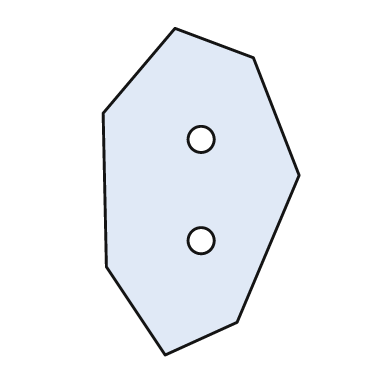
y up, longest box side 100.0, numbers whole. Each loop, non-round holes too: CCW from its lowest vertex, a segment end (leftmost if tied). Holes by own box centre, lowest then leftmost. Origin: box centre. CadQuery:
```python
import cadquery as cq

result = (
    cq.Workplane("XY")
    .moveTo(-11.0, -50.0)
    .lineTo(11.0, -40.0)
    .lineTo(30.0, 5.0)
    .lineTo(16.0, 41.0)
    .lineTo(-8.0, 50.0)
    .lineTo(-30.0, 24.0)
    .lineTo(-29.0, -23.0)
    .close()
    .moveTo(0.0, -15.0)
    .circle(4.0)
    .moveTo(0.0, 16.0)
    .circle(4.0)
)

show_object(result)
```